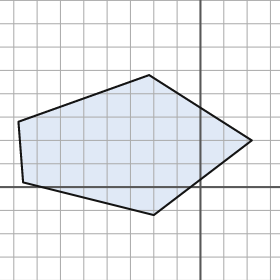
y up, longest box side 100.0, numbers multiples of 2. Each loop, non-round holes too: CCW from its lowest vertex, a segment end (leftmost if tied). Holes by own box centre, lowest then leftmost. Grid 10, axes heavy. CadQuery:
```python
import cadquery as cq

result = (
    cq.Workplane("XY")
    .moveTo(-20.0, -12.0)
    .lineTo(22.0, 20.0)
    .lineTo(-22.0, 48.0)
    .lineTo(-78.0, 28.0)
    .lineTo(-76.0, 2.0)
    .close()
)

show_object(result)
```